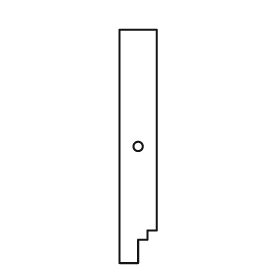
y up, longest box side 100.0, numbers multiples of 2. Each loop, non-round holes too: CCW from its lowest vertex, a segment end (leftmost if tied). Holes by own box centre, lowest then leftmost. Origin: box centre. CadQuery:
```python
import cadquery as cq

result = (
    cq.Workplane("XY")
    .moveTo(-8.0, -50.0)
    .lineTo(0.0, -50.0)
    .lineTo(0.0, -40.0)
    .lineTo(4.0, -40.0)
    .lineTo(4.0, -36.0)
    .lineTo(8.0, -36.0)
    .lineTo(8.0, 50.0)
    .lineTo(-8.0, 50.0)
    .close()
    .moveTo(0.0, 0.0)
    .circle(2.0)
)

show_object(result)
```